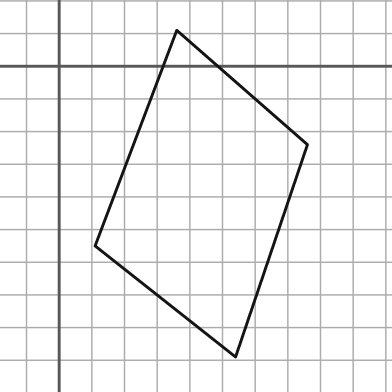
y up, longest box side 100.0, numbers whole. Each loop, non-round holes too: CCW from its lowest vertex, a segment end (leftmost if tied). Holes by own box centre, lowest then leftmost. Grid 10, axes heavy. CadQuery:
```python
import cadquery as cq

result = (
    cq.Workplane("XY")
    .moveTo(54.0, -89.0)
    .lineTo(76.0, -24.0)
    .lineTo(36.0, 11.0)
    .lineTo(11.0, -55.0)
    .close()
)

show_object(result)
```